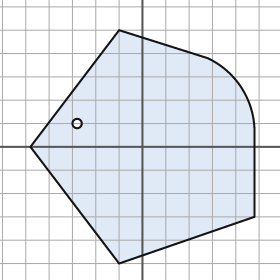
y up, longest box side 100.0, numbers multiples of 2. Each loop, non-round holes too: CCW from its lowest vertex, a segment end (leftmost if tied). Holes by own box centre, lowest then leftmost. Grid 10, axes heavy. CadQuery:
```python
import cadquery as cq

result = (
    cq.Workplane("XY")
    .moveTo(-10.0, -50.0)
    .lineTo(48.0, -30.0)
    .lineTo(48.0, 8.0)
    .threePointArc((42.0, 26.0), (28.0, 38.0))
    .lineTo(-10.0, 50.0)
    .lineTo(-48.0, 0.0)
    .close()
    .moveTo(-28.0, 10.0)
    .circle(2.0)
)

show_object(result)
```